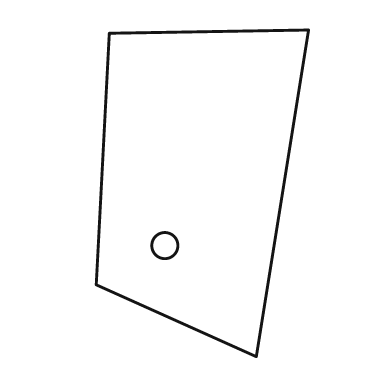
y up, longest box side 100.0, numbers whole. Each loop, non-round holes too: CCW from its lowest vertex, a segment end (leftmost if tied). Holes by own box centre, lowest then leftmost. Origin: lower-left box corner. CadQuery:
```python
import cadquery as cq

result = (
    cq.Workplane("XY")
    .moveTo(49.0, 0.0)
    .lineTo(65.0, 100.0)
    .lineTo(4.0, 99.0)
    .lineTo(0.0, 22.0)
    .close()
    .moveTo(21.0, 34.0)
    .circle(4.0)
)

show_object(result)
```